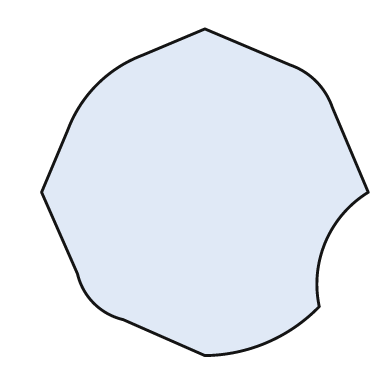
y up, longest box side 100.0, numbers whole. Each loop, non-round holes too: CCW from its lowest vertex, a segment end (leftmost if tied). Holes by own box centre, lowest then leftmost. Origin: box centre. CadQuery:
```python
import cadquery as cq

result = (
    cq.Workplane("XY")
    .moveTo(0.0, -50.0)
    .threePointArc((19.0, -46.0), (35.0, -35.0))
    .threePointArc((37.0, -15.0), (50.0, 0.0))
    .lineTo(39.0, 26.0)
    .threePointArc((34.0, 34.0), (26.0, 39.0))
    .lineTo(0.0, 50.0)
    .lineTo(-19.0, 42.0)
    .threePointArc((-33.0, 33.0), (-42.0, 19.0))
    .lineTo(-50.0, 0.0)
    .lineTo(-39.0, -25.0)
    .threePointArc((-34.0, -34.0), (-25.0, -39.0))
    .close()
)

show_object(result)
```